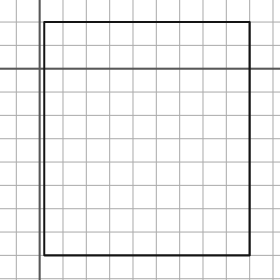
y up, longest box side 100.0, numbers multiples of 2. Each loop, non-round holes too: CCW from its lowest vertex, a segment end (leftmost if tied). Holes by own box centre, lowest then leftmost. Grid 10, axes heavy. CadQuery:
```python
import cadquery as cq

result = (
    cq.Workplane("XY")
    .moveTo(2.0, -80.0)
    .lineTo(90.0, -80.0)
    .lineTo(90.0, 20.0)
    .lineTo(2.0, 20.0)
    .close()
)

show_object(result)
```